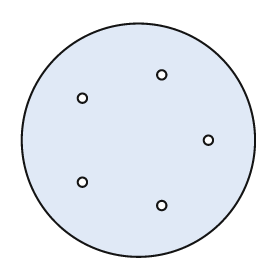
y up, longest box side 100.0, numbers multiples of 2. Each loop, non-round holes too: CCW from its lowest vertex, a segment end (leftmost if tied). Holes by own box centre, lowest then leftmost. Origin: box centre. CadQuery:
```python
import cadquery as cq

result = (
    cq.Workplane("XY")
    .moveTo(0.0, 0.0)
    .circle(50.0)
    .moveTo(10.0, -28.0)
    .circle(2.0)
    .moveTo(-24.0, -18.0)
    .circle(2.0)
    .moveTo(30.0, 0.0)
    .circle(2.0)
    .moveTo(-24.0, 18.0)
    .circle(2.0)
    .moveTo(10.0, 28.0)
    .circle(2.0)
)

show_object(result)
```